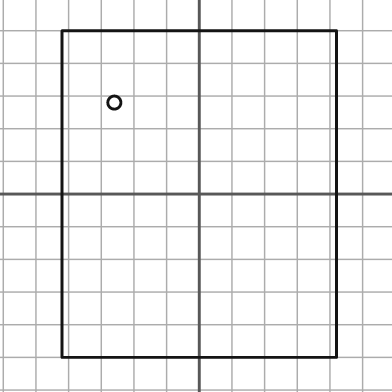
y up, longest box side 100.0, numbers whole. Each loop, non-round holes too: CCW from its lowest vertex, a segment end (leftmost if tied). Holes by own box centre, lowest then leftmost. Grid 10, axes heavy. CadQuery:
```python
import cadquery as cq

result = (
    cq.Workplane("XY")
    .moveTo(-42.0, -50.0)
    .lineTo(42.0, -50.0)
    .lineTo(42.0, 50.0)
    .lineTo(-42.0, 50.0)
    .close()
    .moveTo(-26.0, 28.0)
    .circle(2.0)
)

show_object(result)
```